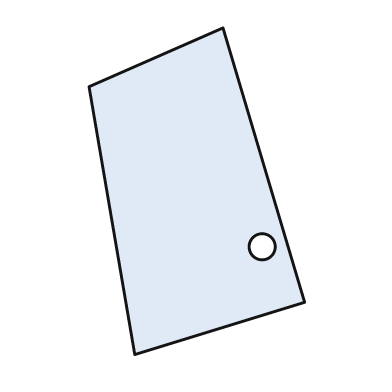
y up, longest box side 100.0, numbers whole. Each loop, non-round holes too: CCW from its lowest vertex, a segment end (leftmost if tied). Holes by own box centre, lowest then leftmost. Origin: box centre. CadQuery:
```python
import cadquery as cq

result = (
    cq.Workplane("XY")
    .moveTo(-19.0, -50.0)
    .lineTo(33.0, -34.0)
    .lineTo(8.0, 50.0)
    .lineTo(-33.0, 32.0)
    .close()
    .moveTo(20.0, -17.0)
    .circle(4.0)
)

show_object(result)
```